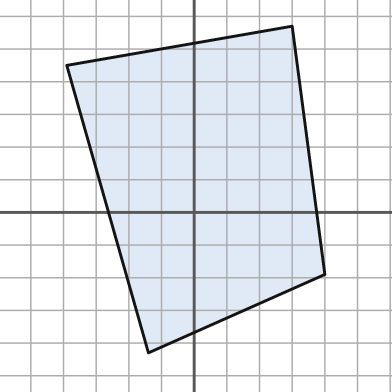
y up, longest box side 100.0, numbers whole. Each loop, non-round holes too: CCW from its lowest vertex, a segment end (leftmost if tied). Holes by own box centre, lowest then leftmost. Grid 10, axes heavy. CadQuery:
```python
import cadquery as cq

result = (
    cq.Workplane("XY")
    .moveTo(-14.0, -43.0)
    .lineTo(40.0, -19.0)
    .lineTo(30.0, 57.0)
    .lineTo(-39.0, 45.0)
    .close()
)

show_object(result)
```